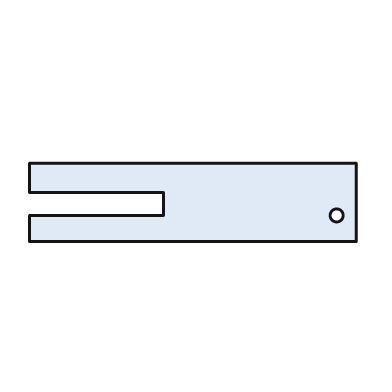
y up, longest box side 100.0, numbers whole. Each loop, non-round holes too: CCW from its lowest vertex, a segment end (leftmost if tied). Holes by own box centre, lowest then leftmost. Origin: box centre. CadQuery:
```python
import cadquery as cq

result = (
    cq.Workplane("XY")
    .moveTo(-50.0, -12.0)
    .lineTo(50.0, -12.0)
    .lineTo(50.0, 12.0)
    .lineTo(-50.0, 12.0)
    .lineTo(-50.0, 3.0)
    .lineTo(-9.0, 3.0)
    .lineTo(-9.0, -4.0)
    .lineTo(-50.0, -4.0)
    .close()
    .moveTo(44.0, -4.0)
    .circle(2.0)
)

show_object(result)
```